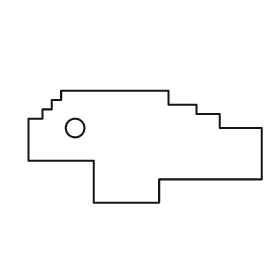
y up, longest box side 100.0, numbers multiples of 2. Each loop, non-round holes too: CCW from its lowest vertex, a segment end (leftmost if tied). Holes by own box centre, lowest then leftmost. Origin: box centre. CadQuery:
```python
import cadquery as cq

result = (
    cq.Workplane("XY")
    .moveTo(-22.0, -24.0)
    .lineTo(6.0, -24.0)
    .lineTo(6.0, -14.0)
    .lineTo(50.0, -14.0)
    .lineTo(50.0, 8.0)
    .lineTo(32.0, 8.0)
    .lineTo(32.0, 14.0)
    .lineTo(22.0, 14.0)
    .lineTo(22.0, 18.0)
    .lineTo(10.0, 18.0)
    .lineTo(10.0, 24.0)
    .lineTo(-36.0, 24.0)
    .lineTo(-36.0, 20.0)
    .lineTo(-40.0, 20.0)
    .lineTo(-40.0, 16.0)
    .lineTo(-44.0, 16.0)
    .lineTo(-44.0, 12.0)
    .lineTo(-50.0, 12.0)
    .lineTo(-50.0, -6.0)
    .lineTo(-22.0, -6.0)
    .close()
    .moveTo(-30.0, 8.0)
    .circle(4.0)
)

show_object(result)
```